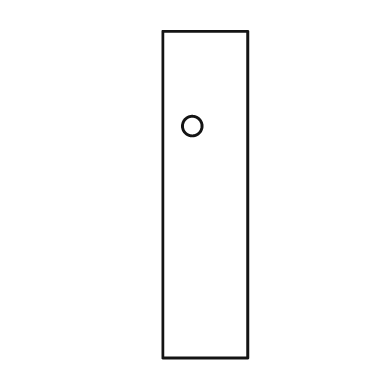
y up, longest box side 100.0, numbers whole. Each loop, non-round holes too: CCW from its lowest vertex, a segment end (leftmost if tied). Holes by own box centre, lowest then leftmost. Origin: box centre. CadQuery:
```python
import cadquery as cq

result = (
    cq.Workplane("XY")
    .moveTo(-13.0, -50.0)
    .lineTo(13.0, -50.0)
    .lineTo(13.0, 50.0)
    .lineTo(-13.0, 50.0)
    .close()
    .moveTo(-4.0, 21.0)
    .circle(3.0)
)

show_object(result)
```